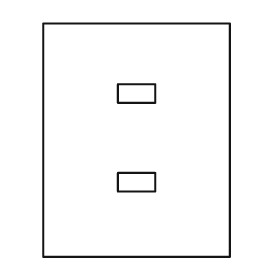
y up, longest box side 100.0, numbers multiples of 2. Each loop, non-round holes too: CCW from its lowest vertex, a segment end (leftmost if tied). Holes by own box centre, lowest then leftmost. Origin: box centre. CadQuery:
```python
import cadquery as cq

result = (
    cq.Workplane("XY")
    .moveTo(-40.0, -50.0)
    .lineTo(40.0, -50.0)
    .lineTo(40.0, 50.0)
    .lineTo(-40.0, 50.0)
    .close()
    .moveTo(-8.0, -22.0)
    .lineTo(8.0, -22.0)
    .lineTo(8.0, -14.0)
    .lineTo(-8.0, -14.0)
    .close()
    .moveTo(-8.0, 16.0)
    .lineTo(8.0, 16.0)
    .lineTo(8.0, 24.0)
    .lineTo(-8.0, 24.0)
    .close()
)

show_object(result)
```